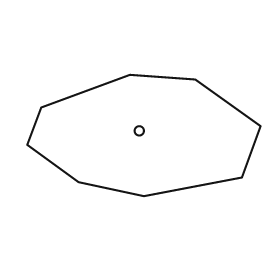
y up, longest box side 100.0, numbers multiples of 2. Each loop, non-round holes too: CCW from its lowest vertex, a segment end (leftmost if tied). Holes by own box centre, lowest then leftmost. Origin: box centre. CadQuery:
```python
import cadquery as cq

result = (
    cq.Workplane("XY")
    .moveTo(0.0, -26.0)
    .lineTo(42.0, -18.0)
    .lineTo(50.0, 4.0)
    .lineTo(22.0, 24.0)
    .lineTo(-6.0, 26.0)
    .lineTo(-44.0, 12.0)
    .lineTo(-50.0, -4.0)
    .lineTo(-28.0, -20.0)
    .close()
    .moveTo(-2.0, 2.0)
    .circle(2.0)
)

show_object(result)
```